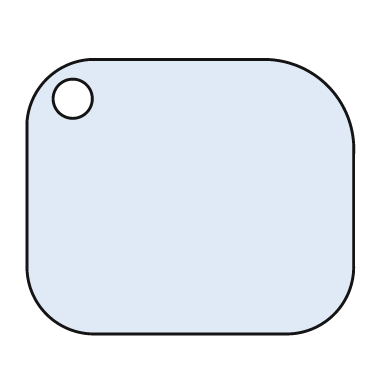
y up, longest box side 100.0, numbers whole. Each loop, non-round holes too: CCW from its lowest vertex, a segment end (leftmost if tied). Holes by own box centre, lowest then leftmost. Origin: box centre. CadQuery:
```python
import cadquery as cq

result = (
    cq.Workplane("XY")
    .moveTo(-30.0, -42.0)
    .lineTo(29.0, -42.0)
    .threePointArc((44.0, -36.0), (50.0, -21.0))
    .lineTo(50.0, 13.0)
    .threePointArc((42.0, 34.0), (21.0, 42.0))
    .lineTo(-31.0, 42.0)
    .threePointArc((-44.0, 36.0), (-50.0, 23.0))
    .lineTo(-50.0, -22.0)
    .threePointArc((-44.0, -36.0), (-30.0, -42.0))
    .close()
    .moveTo(-36.0, 30.0)
    .circle(6.0)
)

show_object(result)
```